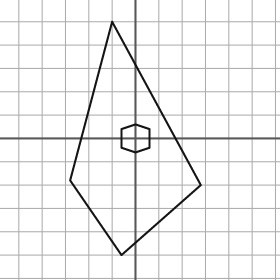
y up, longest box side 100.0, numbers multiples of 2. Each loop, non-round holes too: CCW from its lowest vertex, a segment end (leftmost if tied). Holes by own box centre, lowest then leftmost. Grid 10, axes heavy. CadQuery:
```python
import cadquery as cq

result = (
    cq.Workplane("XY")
    .moveTo(-6.0, -50.0)
    .lineTo(28.0, -20.0)
    .lineTo(-10.0, 50.0)
    .lineTo(-28.0, -18.0)
    .close()
    .moveTo(0.0, -6.0)
    .lineTo(6.0, -4.0)
    .lineTo(6.0, 4.0)
    .lineTo(0.0, 6.0)
    .lineTo(-6.0, 4.0)
    .lineTo(-6.0, -4.0)
    .close()
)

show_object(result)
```